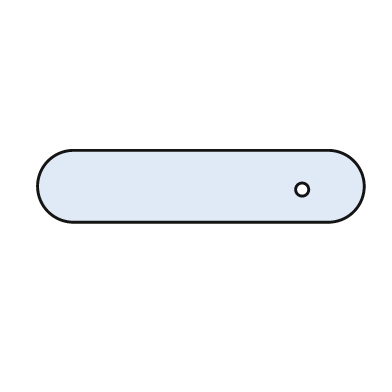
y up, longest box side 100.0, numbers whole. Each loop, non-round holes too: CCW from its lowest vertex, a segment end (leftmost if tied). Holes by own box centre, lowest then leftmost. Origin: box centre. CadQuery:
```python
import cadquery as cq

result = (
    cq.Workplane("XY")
    .moveTo(-39.0, -11.0)
    .lineTo(39.0, -11.0)
    .threePointArc((50.0, 0.0), (39.0, 11.0))
    .lineTo(-39.0, 11.0)
    .threePointArc((-50.0, 0.0), (-39.0, -11.0))
    .close()
    .moveTo(31.0, -1.0)
    .circle(2.0)
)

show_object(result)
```